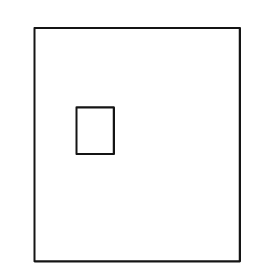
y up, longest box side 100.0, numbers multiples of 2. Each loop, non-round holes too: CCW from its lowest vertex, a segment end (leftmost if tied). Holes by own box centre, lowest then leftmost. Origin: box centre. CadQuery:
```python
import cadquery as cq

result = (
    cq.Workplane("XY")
    .moveTo(-44.0, -50.0)
    .lineTo(44.0, -50.0)
    .lineTo(44.0, 50.0)
    .lineTo(-44.0, 50.0)
    .close()
    .moveTo(-26.0, -4.0)
    .lineTo(-10.0, -4.0)
    .lineTo(-10.0, 16.0)
    .lineTo(-26.0, 16.0)
    .close()
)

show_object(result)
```